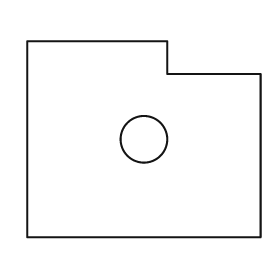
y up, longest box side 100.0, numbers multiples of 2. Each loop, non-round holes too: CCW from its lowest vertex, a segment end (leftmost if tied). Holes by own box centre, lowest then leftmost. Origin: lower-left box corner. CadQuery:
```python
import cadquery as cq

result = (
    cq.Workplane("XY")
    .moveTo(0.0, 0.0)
    .lineTo(100.0, 0.0)
    .lineTo(100.0, 70.0)
    .lineTo(60.0, 70.0)
    .lineTo(60.0, 84.0)
    .lineTo(0.0, 84.0)
    .close()
    .moveTo(50.0, 42.0)
    .circle(10.0)
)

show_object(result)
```